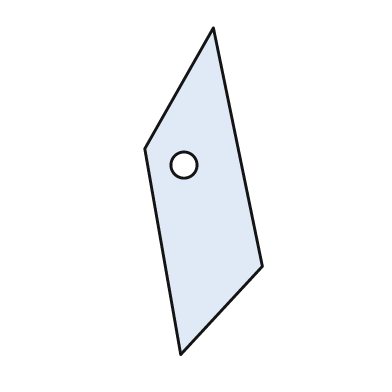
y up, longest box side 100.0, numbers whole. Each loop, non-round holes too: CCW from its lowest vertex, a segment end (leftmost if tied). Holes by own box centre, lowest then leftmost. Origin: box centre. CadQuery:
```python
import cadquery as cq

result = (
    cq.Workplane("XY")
    .moveTo(-7.0, -50.0)
    .lineTo(18.0, -23.0)
    .lineTo(3.0, 50.0)
    .lineTo(-18.0, 13.0)
    .close()
    .moveTo(-6.0, 8.0)
    .circle(4.0)
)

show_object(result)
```